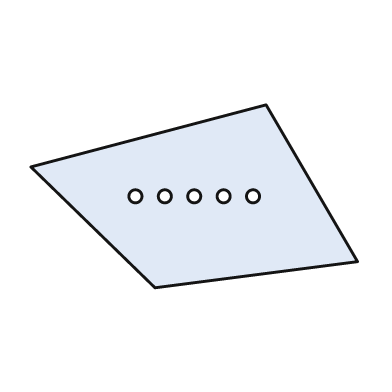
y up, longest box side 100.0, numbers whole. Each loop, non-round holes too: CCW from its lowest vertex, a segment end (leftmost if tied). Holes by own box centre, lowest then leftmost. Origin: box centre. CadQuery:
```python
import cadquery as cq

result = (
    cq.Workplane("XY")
    .moveTo(-12.0, -28.0)
    .lineTo(50.0, -20.0)
    .lineTo(22.0, 28.0)
    .lineTo(-50.0, 9.0)
    .close()
    .moveTo(-18.0, 0.0)
    .circle(2.0)
    .moveTo(-9.0, 0.0)
    .circle(2.0)
    .moveTo(0.0, 0.0)
    .circle(2.0)
    .moveTo(9.0, 0.0)
    .circle(2.0)
    .moveTo(18.0, 0.0)
    .circle(2.0)
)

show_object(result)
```